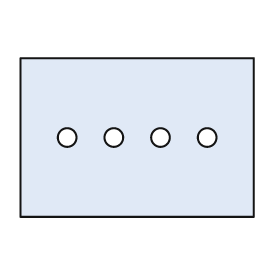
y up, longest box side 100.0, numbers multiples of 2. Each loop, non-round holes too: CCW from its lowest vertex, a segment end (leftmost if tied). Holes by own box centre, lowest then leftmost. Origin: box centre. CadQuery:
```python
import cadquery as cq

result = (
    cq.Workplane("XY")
    .moveTo(-50.0, -34.0)
    .lineTo(50.0, -34.0)
    .lineTo(50.0, 34.0)
    .lineTo(-50.0, 34.0)
    .close()
    .moveTo(-30.0, 0.0)
    .circle(4.0)
    .moveTo(-10.0, 0.0)
    .circle(4.0)
    .moveTo(10.0, 0.0)
    .circle(4.0)
    .moveTo(30.0, 0.0)
    .circle(4.0)
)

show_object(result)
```